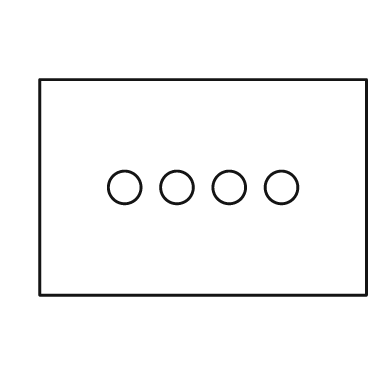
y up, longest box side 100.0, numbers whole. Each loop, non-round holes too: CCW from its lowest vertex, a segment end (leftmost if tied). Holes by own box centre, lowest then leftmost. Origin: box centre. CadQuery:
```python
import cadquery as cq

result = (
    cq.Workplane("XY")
    .moveTo(-50.0, -33.0)
    .lineTo(50.0, -33.0)
    .lineTo(50.0, 33.0)
    .lineTo(-50.0, 33.0)
    .close()
    .moveTo(-24.0, 0.0)
    .circle(5.0)
    .moveTo(-8.0, 0.0)
    .circle(5.0)
    .moveTo(8.0, 0.0)
    .circle(5.0)
    .moveTo(24.0, 0.0)
    .circle(5.0)
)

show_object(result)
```